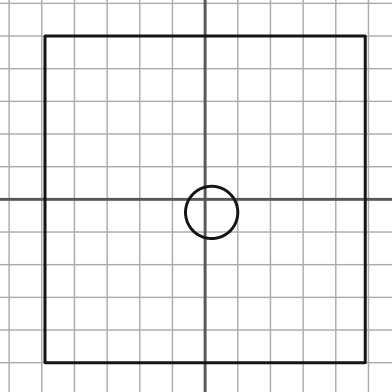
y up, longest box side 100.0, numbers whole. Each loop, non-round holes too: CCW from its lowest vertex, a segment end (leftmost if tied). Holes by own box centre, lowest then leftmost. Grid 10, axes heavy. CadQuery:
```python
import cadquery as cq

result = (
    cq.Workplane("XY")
    .moveTo(-49.0, -50.0)
    .lineTo(49.0, -50.0)
    .lineTo(49.0, 50.0)
    .lineTo(-49.0, 50.0)
    .close()
    .moveTo(2.0, -4.0)
    .circle(8.0)
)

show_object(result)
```